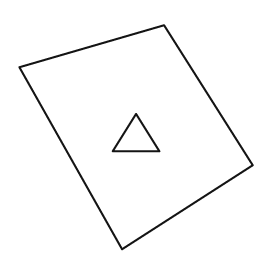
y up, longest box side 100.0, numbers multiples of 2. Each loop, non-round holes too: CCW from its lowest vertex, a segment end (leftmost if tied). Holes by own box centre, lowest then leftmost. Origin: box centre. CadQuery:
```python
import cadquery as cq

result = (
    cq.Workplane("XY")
    .moveTo(-6.0, -48.0)
    .lineTo(50.0, -12.0)
    .lineTo(12.0, 48.0)
    .lineTo(-50.0, 30.0)
    .close()
    .moveTo(-10.0, -6.0)
    .lineTo(10.0, -6.0)
    .lineTo(0.0, 10.0)
    .close()
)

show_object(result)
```